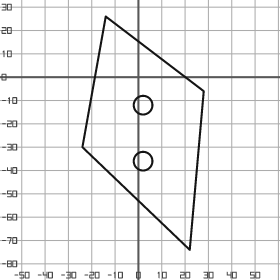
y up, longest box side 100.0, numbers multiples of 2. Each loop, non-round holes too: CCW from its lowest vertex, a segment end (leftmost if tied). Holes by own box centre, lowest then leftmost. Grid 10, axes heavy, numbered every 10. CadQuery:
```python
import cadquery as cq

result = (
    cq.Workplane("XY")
    .moveTo(22.0, -74.0)
    .lineTo(28.0, -6.0)
    .lineTo(-14.0, 26.0)
    .lineTo(-24.0, -30.0)
    .close()
    .moveTo(2.0, -36.0)
    .circle(4.0)
    .moveTo(2.0, -12.0)
    .circle(4.0)
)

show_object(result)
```